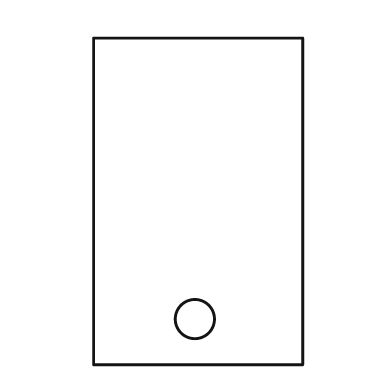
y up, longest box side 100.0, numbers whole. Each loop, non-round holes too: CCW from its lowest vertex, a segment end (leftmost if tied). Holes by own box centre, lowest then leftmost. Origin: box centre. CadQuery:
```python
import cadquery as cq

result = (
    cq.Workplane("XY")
    .moveTo(-32.0, -50.0)
    .lineTo(32.0, -50.0)
    .lineTo(32.0, 50.0)
    .lineTo(-32.0, 50.0)
    .close()
    .moveTo(-1.0, -36.0)
    .circle(6.0)
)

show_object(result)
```